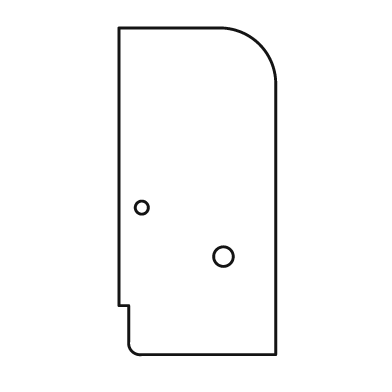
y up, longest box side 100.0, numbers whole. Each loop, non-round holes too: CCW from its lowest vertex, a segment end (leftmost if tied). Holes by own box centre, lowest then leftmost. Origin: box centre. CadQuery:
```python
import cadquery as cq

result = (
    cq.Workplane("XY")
    .moveTo(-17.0, -50.0)
    .lineTo(24.0, -50.0)
    .lineTo(24.0, 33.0)
    .threePointArc((19.0, 45.0), (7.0, 50.0))
    .lineTo(-24.0, 50.0)
    .lineTo(-24.0, -35.0)
    .lineTo(-21.0, -35.0)
    .lineTo(-21.0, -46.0)
    .threePointArc((-20.0, -49.0), (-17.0, -50.0))
    .close()
    .moveTo(8.0, -20.0)
    .circle(3.0)
    .moveTo(-17.0, -5.0)
    .circle(2.0)
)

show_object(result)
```